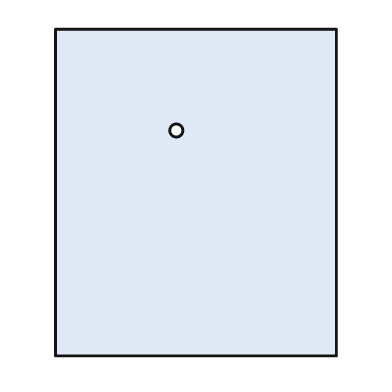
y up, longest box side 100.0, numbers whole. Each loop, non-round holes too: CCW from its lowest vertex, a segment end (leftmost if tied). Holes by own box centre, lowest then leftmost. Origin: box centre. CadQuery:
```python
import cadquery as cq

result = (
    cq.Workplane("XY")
    .moveTo(-43.0, -50.0)
    .lineTo(43.0, -50.0)
    .lineTo(43.0, 50.0)
    .lineTo(-43.0, 50.0)
    .close()
    .moveTo(-6.0, 19.0)
    .circle(2.0)
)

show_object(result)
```